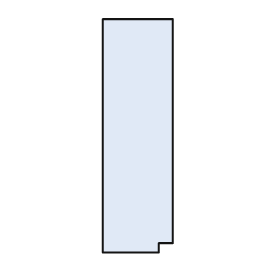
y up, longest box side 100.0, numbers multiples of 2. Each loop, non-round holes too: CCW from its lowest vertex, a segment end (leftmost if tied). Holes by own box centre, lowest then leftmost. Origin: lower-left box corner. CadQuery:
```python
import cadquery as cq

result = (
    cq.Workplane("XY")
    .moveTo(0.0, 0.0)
    .lineTo(24.0, 0.0)
    .lineTo(24.0, 4.0)
    .lineTo(30.0, 4.0)
    .lineTo(30.0, 100.0)
    .lineTo(0.0, 100.0)
    .close()
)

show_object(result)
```